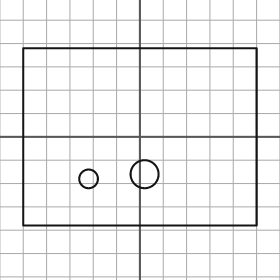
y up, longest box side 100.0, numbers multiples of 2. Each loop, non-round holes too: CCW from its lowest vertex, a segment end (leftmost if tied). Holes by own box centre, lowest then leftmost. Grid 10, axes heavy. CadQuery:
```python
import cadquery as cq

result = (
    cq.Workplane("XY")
    .moveTo(-50.0, -38.0)
    .lineTo(50.0, -38.0)
    .lineTo(50.0, 38.0)
    .lineTo(-50.0, 38.0)
    .close()
    .moveTo(-22.0, -18.0)
    .circle(4.0)
    .moveTo(2.0, -16.0)
    .circle(6.0)
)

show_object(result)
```